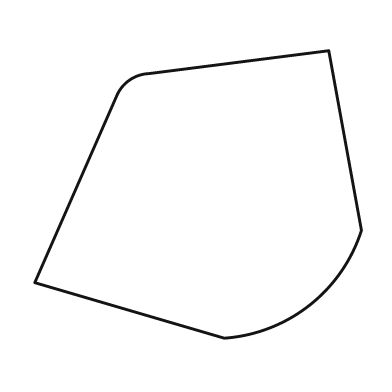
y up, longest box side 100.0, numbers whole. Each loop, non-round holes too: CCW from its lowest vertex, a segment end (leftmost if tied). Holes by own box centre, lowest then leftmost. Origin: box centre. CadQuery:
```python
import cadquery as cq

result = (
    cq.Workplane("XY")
    .moveTo(8.0, -44.0)
    .threePointArc((34.0, -34.0), (50.0, -11.0))
    .lineTo(40.0, 44.0)
    .lineTo(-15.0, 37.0)
    .threePointArc((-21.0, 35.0), (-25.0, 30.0))
    .lineTo(-50.0, -27.0)
    .close()
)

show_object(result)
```